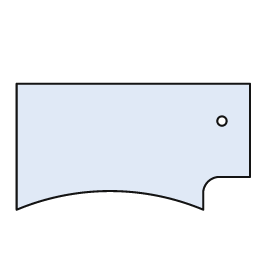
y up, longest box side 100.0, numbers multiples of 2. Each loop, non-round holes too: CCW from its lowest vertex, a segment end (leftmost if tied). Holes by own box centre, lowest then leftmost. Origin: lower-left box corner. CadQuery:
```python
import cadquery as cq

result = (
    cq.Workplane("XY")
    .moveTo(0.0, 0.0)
    .threePointArc((40.0, 8.0), (80.0, 0.0))
    .lineTo(80.0, 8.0)
    .threePointArc((82.0, 12.0), (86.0, 14.0))
    .lineTo(100.0, 14.0)
    .lineTo(100.0, 54.0)
    .lineTo(0.0, 54.0)
    .close()
    .moveTo(88.0, 38.0)
    .circle(2.0)
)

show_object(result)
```